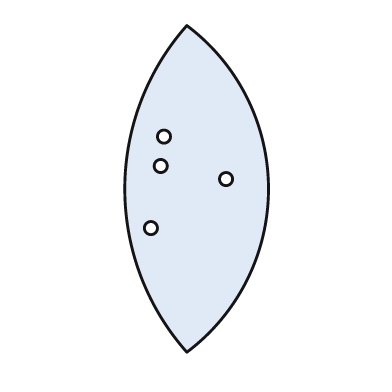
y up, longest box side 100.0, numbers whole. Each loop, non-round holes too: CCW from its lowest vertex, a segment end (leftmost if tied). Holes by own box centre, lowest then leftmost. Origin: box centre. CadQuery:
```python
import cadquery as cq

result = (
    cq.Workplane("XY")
    .moveTo(-3.0, -50.0)
    .threePointArc((22.0, 0.0), (-3.0, 50.0))
    .threePointArc((-22.0, 0.0), (-3.0, -50.0))
    .close()
    .moveTo(-14.0, -12.0)
    .circle(2.0)
    .moveTo(9.0, 3.0)
    .circle(2.0)
    .moveTo(-11.0, 7.0)
    .circle(2.0)
    .moveTo(-10.0, 16.0)
    .circle(2.0)
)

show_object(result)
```